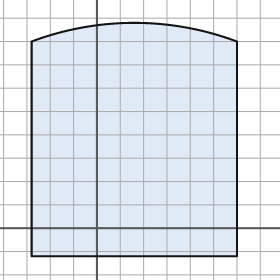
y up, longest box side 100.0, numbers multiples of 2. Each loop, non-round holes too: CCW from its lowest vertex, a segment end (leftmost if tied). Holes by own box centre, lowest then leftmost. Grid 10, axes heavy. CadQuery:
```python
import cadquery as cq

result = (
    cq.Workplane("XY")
    .moveTo(-28.0, -12.0)
    .lineTo(60.0, -12.0)
    .lineTo(60.0, 80.0)
    .threePointArc((16.0, 88.0), (-28.0, 80.0))
    .close()
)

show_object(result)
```